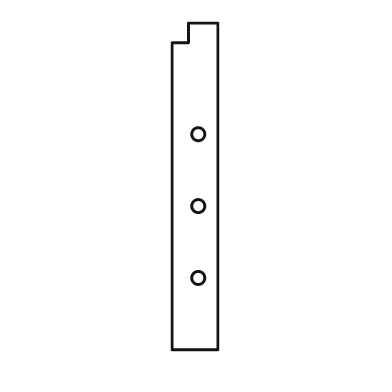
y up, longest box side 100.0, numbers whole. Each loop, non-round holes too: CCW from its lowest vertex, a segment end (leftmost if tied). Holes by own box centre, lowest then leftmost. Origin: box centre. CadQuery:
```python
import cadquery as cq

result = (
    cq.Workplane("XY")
    .moveTo(-7.0, -50.0)
    .lineTo(7.0, -50.0)
    .lineTo(7.0, 50.0)
    .lineTo(-2.0, 50.0)
    .lineTo(-2.0, 44.0)
    .lineTo(-7.0, 44.0)
    .close()
    .moveTo(1.0, -28.0)
    .circle(2.0)
    .moveTo(1.0, -6.0)
    .circle(2.0)
    .moveTo(1.0, 16.0)
    .circle(2.0)
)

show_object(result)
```